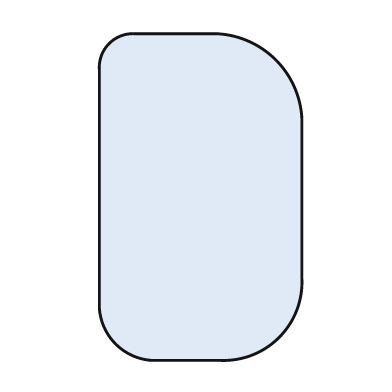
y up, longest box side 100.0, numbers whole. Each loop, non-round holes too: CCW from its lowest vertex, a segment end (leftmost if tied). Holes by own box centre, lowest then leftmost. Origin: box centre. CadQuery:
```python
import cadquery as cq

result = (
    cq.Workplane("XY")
    .moveTo(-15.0, -50.0)
    .lineTo(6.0, -50.0)
    .threePointArc((24.0, -43.0), (31.0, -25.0))
    .lineTo(31.0, 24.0)
    .threePointArc((23.0, 42.0), (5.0, 50.0))
    .lineTo(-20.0, 50.0)
    .threePointArc((-28.0, 47.0), (-31.0, 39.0))
    .lineTo(-31.0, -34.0)
    .threePointArc((-26.0, -45.0), (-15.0, -50.0))
    .close()
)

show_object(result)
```